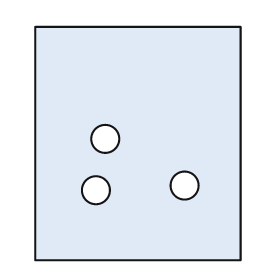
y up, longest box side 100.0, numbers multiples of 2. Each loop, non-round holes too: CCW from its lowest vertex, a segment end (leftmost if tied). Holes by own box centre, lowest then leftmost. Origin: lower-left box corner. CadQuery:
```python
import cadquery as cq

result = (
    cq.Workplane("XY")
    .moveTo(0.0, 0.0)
    .lineTo(88.0, 0.0)
    .lineTo(88.0, 100.0)
    .lineTo(0.0, 100.0)
    .close()
    .moveTo(26.0, 30.0)
    .circle(6.0)
    .moveTo(64.0, 32.0)
    .circle(6.0)
    .moveTo(30.0, 52.0)
    .circle(6.0)
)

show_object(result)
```